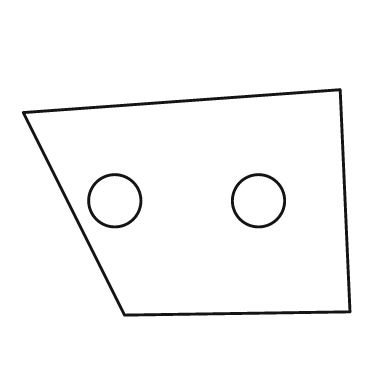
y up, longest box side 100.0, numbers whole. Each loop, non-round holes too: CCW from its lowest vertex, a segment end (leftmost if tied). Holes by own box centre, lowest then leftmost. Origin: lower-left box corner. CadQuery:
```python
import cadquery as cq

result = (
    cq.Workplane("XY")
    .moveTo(31.0, 0.0)
    .lineTo(100.0, 1.0)
    .lineTo(97.0, 69.0)
    .lineTo(0.0, 62.0)
    .close()
    .moveTo(28.0, 35.0)
    .circle(8.0)
    .moveTo(72.0, 35.0)
    .circle(8.0)
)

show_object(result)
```